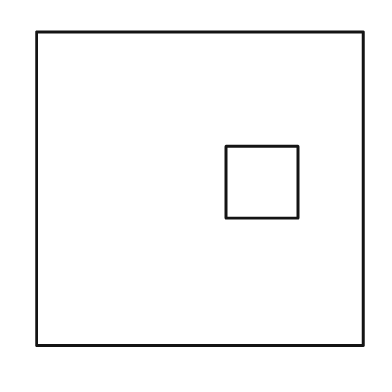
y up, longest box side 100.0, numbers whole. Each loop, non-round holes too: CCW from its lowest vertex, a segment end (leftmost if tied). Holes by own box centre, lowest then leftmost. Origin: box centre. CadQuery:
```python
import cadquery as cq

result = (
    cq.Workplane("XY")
    .moveTo(-50.0, -48.0)
    .lineTo(50.0, -48.0)
    .lineTo(50.0, 48.0)
    .lineTo(-50.0, 48.0)
    .close()
    .moveTo(8.0, -9.0)
    .lineTo(30.0, -9.0)
    .lineTo(30.0, 13.0)
    .lineTo(8.0, 13.0)
    .close()
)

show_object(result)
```